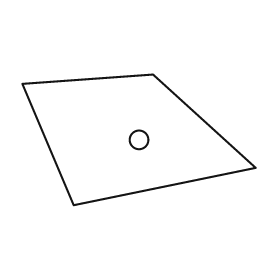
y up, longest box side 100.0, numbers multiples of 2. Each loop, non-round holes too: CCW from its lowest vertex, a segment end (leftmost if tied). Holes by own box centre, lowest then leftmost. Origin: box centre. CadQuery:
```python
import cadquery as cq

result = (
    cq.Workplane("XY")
    .moveTo(-28.0, -28.0)
    .lineTo(50.0, -12.0)
    .lineTo(6.0, 28.0)
    .lineTo(-50.0, 24.0)
    .close()
    .moveTo(0.0, 0.0)
    .circle(4.0)
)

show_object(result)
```